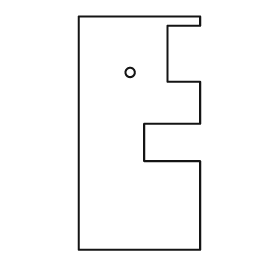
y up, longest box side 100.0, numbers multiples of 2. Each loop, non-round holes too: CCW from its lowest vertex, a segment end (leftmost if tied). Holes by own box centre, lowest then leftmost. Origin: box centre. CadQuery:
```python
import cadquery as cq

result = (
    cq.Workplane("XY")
    .moveTo(-26.0, -50.0)
    .lineTo(26.0, -50.0)
    .lineTo(26.0, -12.0)
    .lineTo(2.0, -12.0)
    .lineTo(2.0, 4.0)
    .lineTo(26.0, 4.0)
    .lineTo(26.0, 22.0)
    .lineTo(12.0, 22.0)
    .lineTo(12.0, 46.0)
    .lineTo(26.0, 46.0)
    .lineTo(26.0, 50.0)
    .lineTo(-26.0, 50.0)
    .close()
    .moveTo(-4.0, 26.0)
    .circle(2.0)
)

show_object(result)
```